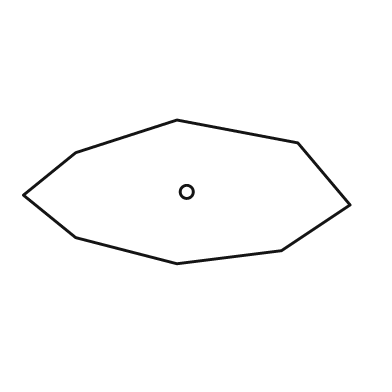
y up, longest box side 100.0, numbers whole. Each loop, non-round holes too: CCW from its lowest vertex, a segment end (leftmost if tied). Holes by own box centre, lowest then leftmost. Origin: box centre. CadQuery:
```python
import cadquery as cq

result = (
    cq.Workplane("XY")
    .moveTo(-3.0, -22.0)
    .lineTo(29.0, -18.0)
    .lineTo(50.0, -4.0)
    .lineTo(34.0, 15.0)
    .lineTo(-3.0, 22.0)
    .lineTo(-34.0, 12.0)
    .lineTo(-50.0, -1.0)
    .lineTo(-34.0, -14.0)
    .close()
    .moveTo(0.0, 0.0)
    .circle(2.0)
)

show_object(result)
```